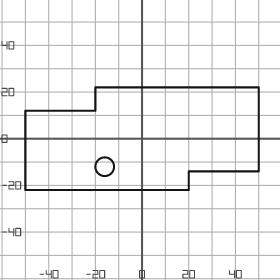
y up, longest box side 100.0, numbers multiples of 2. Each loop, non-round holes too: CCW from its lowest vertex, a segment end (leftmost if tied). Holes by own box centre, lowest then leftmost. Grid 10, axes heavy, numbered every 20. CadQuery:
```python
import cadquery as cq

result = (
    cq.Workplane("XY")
    .moveTo(-50.0, -22.0)
    .lineTo(20.0, -22.0)
    .lineTo(20.0, -14.0)
    .lineTo(50.0, -14.0)
    .lineTo(50.0, 22.0)
    .lineTo(-20.0, 22.0)
    .lineTo(-20.0, 12.0)
    .lineTo(-50.0, 12.0)
    .close()
    .moveTo(-16.0, -12.0)
    .circle(4.0)
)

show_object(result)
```